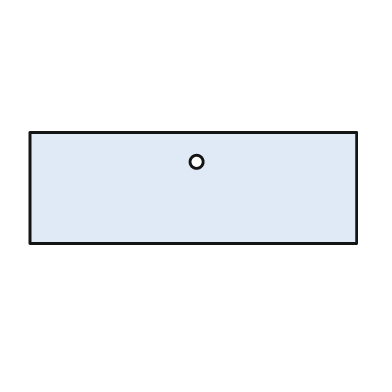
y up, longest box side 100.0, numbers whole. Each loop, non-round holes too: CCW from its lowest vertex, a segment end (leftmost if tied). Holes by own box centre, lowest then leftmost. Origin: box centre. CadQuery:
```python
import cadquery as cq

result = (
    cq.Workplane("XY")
    .moveTo(-50.0, -17.0)
    .lineTo(50.0, -17.0)
    .lineTo(50.0, 17.0)
    .lineTo(-50.0, 17.0)
    .close()
    .moveTo(1.0, 8.0)
    .circle(2.0)
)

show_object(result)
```